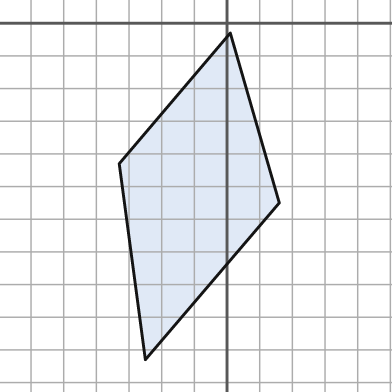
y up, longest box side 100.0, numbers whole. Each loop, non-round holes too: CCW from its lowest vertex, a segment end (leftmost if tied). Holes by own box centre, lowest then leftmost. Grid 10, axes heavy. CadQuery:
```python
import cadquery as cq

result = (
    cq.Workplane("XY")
    .moveTo(-25.0, -103.0)
    .lineTo(16.0, -55.0)
    .lineTo(1.0, -3.0)
    .lineTo(-33.0, -43.0)
    .close()
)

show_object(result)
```